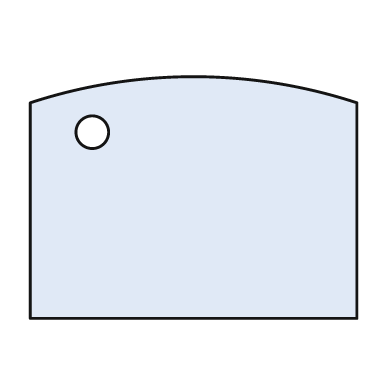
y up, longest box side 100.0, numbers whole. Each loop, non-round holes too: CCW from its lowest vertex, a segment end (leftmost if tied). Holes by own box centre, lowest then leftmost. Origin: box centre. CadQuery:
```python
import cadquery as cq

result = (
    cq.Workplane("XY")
    .moveTo(-50.0, -37.0)
    .lineTo(50.0, -37.0)
    .lineTo(50.0, 29.0)
    .threePointArc((0.0, 37.0), (-50.0, 29.0))
    .close()
    .moveTo(-31.0, 20.0)
    .circle(5.0)
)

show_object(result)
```